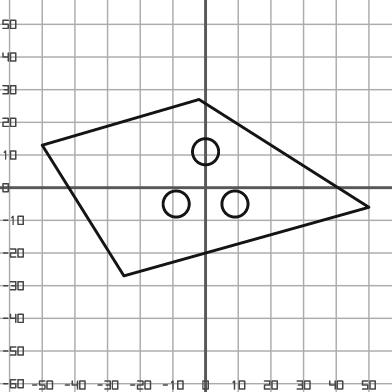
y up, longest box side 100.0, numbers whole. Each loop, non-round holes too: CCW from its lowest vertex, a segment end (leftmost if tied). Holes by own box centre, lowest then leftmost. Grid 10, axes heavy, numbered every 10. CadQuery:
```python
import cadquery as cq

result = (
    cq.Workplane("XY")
    .moveTo(-25.0, -27.0)
    .lineTo(50.0, -6.0)
    .lineTo(-2.0, 27.0)
    .lineTo(-50.0, 13.0)
    .close()
    .moveTo(-9.0, -5.0)
    .circle(4.0)
    .moveTo(9.0, -5.0)
    .circle(4.0)
    .moveTo(0.0, 11.0)
    .circle(4.0)
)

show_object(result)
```